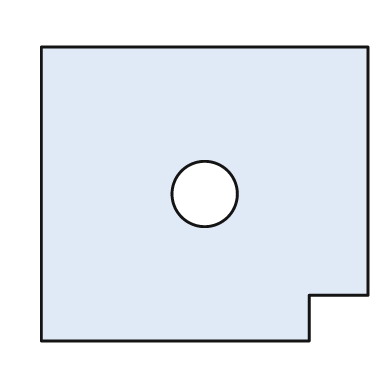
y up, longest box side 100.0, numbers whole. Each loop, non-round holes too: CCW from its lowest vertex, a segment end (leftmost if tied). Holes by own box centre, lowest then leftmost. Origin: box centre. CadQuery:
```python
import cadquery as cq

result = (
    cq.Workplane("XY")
    .moveTo(-50.0, -45.0)
    .lineTo(32.0, -45.0)
    .lineTo(32.0, -31.0)
    .lineTo(50.0, -31.0)
    .lineTo(50.0, 45.0)
    .lineTo(-50.0, 45.0)
    .close()
    .moveTo(0.0, 0.0)
    .circle(10.0)
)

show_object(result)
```